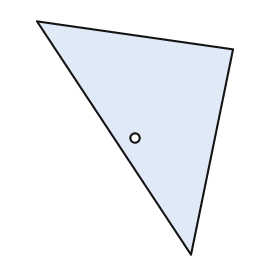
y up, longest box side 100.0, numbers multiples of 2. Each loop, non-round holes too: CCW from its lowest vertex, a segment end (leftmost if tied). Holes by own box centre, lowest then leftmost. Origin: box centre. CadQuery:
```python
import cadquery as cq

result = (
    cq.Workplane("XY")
    .moveTo(24.0, -50.0)
    .lineTo(42.0, 38.0)
    .lineTo(-42.0, 50.0)
    .close()
    .moveTo(0.0, 0.0)
    .circle(2.0)
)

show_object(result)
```